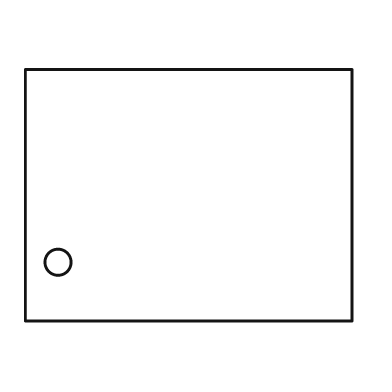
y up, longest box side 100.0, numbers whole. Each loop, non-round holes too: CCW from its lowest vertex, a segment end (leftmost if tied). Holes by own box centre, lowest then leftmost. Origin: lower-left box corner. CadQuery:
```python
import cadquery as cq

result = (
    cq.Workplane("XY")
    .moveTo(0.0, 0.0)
    .lineTo(100.0, 0.0)
    .lineTo(100.0, 77.0)
    .lineTo(0.0, 77.0)
    .close()
    .moveTo(10.0, 18.0)
    .circle(4.0)
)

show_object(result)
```